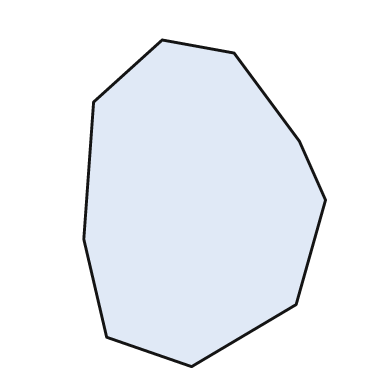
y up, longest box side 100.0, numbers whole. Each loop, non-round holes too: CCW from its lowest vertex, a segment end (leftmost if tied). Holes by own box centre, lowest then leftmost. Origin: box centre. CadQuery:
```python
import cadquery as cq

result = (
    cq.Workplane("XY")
    .moveTo(-4.0, -50.0)
    .lineTo(28.0, -31.0)
    .lineTo(37.0, 1.0)
    .lineTo(29.0, 19.0)
    .lineTo(9.0, 46.0)
    .lineTo(-13.0, 50.0)
    .lineTo(-34.0, 31.0)
    .lineTo(-37.0, -11.0)
    .lineTo(-30.0, -41.0)
    .close()
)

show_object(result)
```